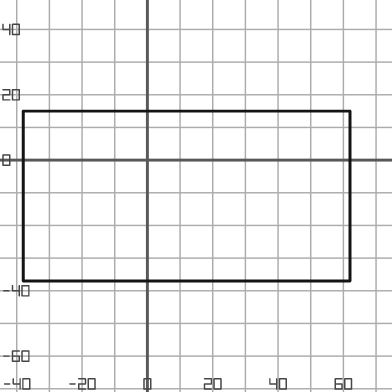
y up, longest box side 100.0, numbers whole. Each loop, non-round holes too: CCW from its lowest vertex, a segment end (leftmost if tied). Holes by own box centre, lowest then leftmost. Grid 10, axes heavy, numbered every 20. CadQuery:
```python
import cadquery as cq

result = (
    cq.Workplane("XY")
    .moveTo(-38.0, -37.0)
    .lineTo(62.0, -37.0)
    .lineTo(62.0, 15.0)
    .lineTo(-38.0, 15.0)
    .close()
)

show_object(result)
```